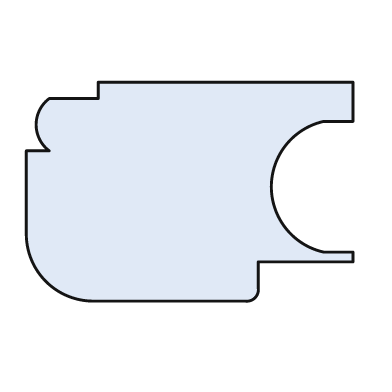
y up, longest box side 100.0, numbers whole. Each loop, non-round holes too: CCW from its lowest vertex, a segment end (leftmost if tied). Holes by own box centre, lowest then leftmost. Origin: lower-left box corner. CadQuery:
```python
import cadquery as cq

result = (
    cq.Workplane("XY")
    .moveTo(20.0, 0.0)
    .lineTo(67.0, 0.0)
    .threePointArc((70.0, 1.0), (71.0, 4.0))
    .lineTo(71.0, 12.0)
    .lineTo(100.0, 12.0)
    .lineTo(100.0, 15.0)
    .lineTo(91.0, 15.0)
    .threePointArc((75.0, 35.0), (91.0, 55.0))
    .lineTo(100.0, 55.0)
    .lineTo(100.0, 67.0)
    .lineTo(22.0, 67.0)
    .lineTo(22.0, 62.0)
    .lineTo(7.0, 62.0)
    .threePointArc((3.0, 54.0), (7.0, 46.0))
    .lineTo(0.0, 46.0)
    .lineTo(0.0, 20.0)
    .threePointArc((6.0, 6.0), (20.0, 0.0))
    .close()
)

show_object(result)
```